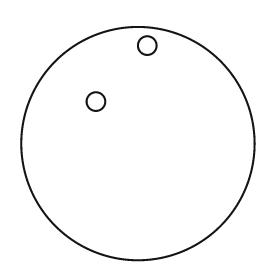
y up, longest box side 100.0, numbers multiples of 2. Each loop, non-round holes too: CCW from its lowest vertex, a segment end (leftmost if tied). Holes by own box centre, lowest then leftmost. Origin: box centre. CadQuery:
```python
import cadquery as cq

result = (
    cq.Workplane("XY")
    .moveTo(0.0, 0.0)
    .circle(50.0)
    .moveTo(-18.0, 18.0)
    .circle(4.0)
    .moveTo(4.0, 42.0)
    .circle(4.0)
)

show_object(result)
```